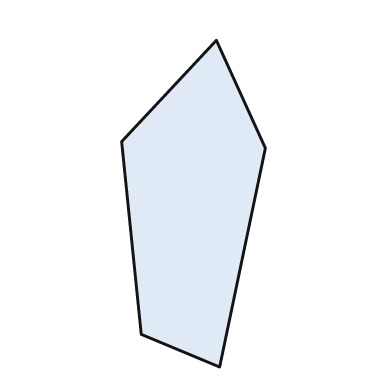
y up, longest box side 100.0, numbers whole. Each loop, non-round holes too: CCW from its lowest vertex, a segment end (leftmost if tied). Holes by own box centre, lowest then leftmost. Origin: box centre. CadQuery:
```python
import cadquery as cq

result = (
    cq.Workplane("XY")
    .moveTo(8.0, -50.0)
    .lineTo(22.0, 17.0)
    .lineTo(7.0, 50.0)
    .lineTo(-22.0, 19.0)
    .lineTo(-16.0, -40.0)
    .close()
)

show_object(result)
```